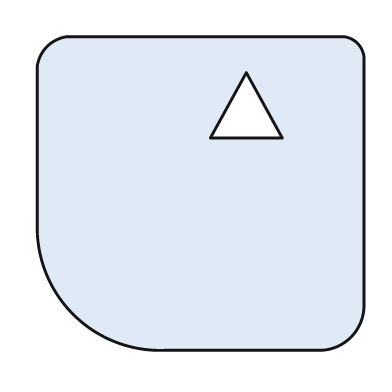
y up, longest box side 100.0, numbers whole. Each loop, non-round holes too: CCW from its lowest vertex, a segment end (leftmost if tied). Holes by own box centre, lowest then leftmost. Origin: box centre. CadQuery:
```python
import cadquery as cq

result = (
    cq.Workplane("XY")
    .moveTo(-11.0, -48.0)
    .lineTo(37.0, -48.0)
    .threePointArc((46.0, -44.0), (50.0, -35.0))
    .lineTo(50.0, 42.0)
    .threePointArc((48.0, 46.0), (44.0, 48.0))
    .lineTo(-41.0, 48.0)
    .threePointArc((-47.0, 45.0), (-50.0, 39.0))
    .lineTo(-50.0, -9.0)
    .threePointArc((-39.0, -37.0), (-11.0, -48.0))
    .close()
    .moveTo(3.0, 17.0)
    .lineTo(25.0, 17.0)
    .lineTo(14.0, 37.0)
    .close()
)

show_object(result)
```